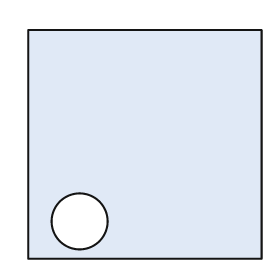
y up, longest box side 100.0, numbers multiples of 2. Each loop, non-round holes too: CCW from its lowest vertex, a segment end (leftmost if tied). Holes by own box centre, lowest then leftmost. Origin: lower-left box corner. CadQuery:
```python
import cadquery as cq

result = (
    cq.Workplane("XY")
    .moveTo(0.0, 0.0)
    .lineTo(100.0, 0.0)
    .lineTo(100.0, 98.0)
    .lineTo(0.0, 98.0)
    .close()
    .moveTo(22.0, 16.0)
    .circle(12.0)
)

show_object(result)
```